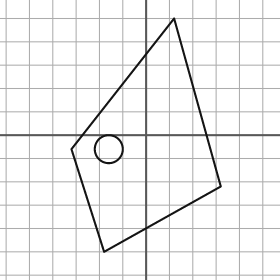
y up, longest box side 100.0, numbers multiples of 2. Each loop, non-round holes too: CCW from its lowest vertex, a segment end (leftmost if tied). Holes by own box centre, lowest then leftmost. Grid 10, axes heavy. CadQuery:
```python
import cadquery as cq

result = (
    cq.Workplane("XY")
    .moveTo(-18.0, -50.0)
    .lineTo(32.0, -22.0)
    .lineTo(12.0, 50.0)
    .lineTo(-32.0, -6.0)
    .close()
    .moveTo(-16.0, -6.0)
    .circle(6.0)
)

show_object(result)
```